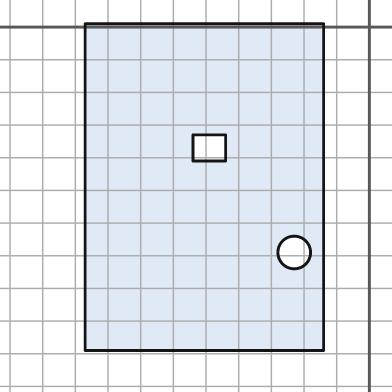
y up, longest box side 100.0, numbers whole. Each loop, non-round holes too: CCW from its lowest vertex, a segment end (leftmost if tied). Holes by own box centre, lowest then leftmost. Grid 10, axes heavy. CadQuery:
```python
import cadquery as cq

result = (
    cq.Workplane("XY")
    .moveTo(-87.0, -99.0)
    .lineTo(-14.0, -99.0)
    .lineTo(-14.0, 1.0)
    .lineTo(-87.0, 1.0)
    .close()
    .moveTo(-23.0, -69.0)
    .circle(5.0)
    .moveTo(-54.0, -41.0)
    .lineTo(-44.0, -41.0)
    .lineTo(-44.0, -33.0)
    .lineTo(-54.0, -33.0)
    .close()
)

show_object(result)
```